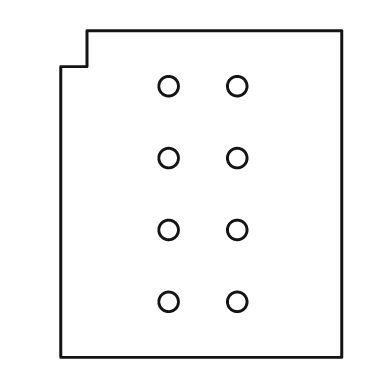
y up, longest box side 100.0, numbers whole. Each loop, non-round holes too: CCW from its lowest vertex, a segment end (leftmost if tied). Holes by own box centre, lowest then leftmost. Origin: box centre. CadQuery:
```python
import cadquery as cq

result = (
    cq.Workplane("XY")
    .moveTo(-43.0, -50.0)
    .lineTo(43.0, -50.0)
    .lineTo(43.0, 50.0)
    .lineTo(-35.0, 50.0)
    .lineTo(-35.0, 39.0)
    .lineTo(-43.0, 39.0)
    .close()
    .moveTo(-10.0, -33.0)
    .circle(3.0)
    .moveTo(11.0, -33.0)
    .circle(3.0)
    .moveTo(-10.0, -11.0)
    .circle(3.0)
    .moveTo(11.0, -11.0)
    .circle(3.0)
    .moveTo(-10.0, 11.0)
    .circle(3.0)
    .moveTo(11.0, 11.0)
    .circle(3.0)
    .moveTo(-10.0, 33.0)
    .circle(3.0)
    .moveTo(11.0, 33.0)
    .circle(3.0)
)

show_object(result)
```